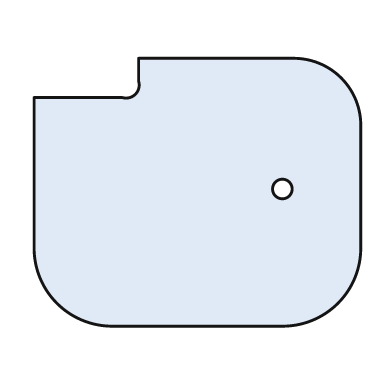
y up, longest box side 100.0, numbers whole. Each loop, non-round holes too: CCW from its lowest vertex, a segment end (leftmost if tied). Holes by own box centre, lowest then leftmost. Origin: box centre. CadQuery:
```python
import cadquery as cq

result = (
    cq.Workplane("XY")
    .moveTo(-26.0, -41.0)
    .lineTo(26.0, -41.0)
    .threePointArc((43.0, -34.0), (50.0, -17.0))
    .lineTo(50.0, 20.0)
    .threePointArc((44.0, 35.0), (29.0, 41.0))
    .lineTo(-18.0, 41.0)
    .lineTo(-18.0, 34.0)
    .threePointArc((-19.0, 30.0), (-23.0, 29.0))
    .lineTo(-50.0, 29.0)
    .lineTo(-50.0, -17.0)
    .threePointArc((-43.0, -34.0), (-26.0, -41.0))
    .close()
    .moveTo(26.0, 1.0)
    .circle(3.0)
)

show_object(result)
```